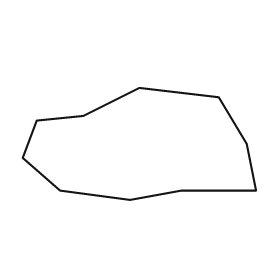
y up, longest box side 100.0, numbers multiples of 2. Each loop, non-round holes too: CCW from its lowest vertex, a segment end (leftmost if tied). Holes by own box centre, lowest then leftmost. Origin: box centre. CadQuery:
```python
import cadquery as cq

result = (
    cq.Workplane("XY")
    .moveTo(-4.0, -24.0)
    .lineTo(18.0, -20.0)
    .lineTo(50.0, -20.0)
    .lineTo(46.0, 0.0)
    .lineTo(34.0, 20.0)
    .lineTo(0.0, 24.0)
    .lineTo(-24.0, 12.0)
    .lineTo(-44.0, 10.0)
    .lineTo(-50.0, -6.0)
    .lineTo(-34.0, -20.0)
    .close()
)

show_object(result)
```